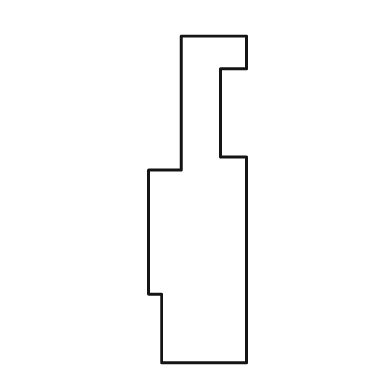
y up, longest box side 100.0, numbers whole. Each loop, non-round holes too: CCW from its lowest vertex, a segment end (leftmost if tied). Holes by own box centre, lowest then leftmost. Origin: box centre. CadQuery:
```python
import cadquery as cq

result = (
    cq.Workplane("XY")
    .moveTo(-11.0, -50.0)
    .lineTo(15.0, -50.0)
    .lineTo(15.0, 13.0)
    .lineTo(7.0, 13.0)
    .lineTo(7.0, 40.0)
    .lineTo(15.0, 40.0)
    .lineTo(15.0, 50.0)
    .lineTo(-5.0, 50.0)
    .lineTo(-5.0, 9.0)
    .lineTo(-15.0, 9.0)
    .lineTo(-15.0, -29.0)
    .lineTo(-11.0, -29.0)
    .close()
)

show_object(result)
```